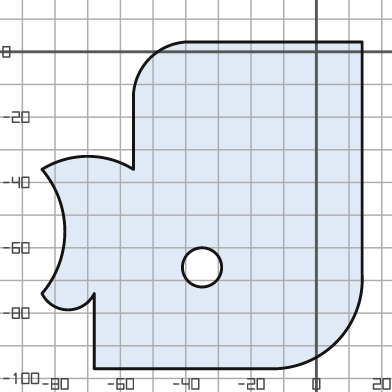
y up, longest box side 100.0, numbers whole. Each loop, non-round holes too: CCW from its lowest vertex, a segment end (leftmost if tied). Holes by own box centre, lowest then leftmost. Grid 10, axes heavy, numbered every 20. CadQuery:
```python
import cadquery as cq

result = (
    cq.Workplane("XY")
    .moveTo(-68.0, -97.0)
    .lineTo(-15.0, -97.0)
    .threePointArc((6.0, -89.0), (14.0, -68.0))
    .lineTo(14.0, 3.0)
    .lineTo(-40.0, 3.0)
    .threePointArc((-51.0, -2.0), (-56.0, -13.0))
    .lineTo(-56.0, -36.0)
    .threePointArc((-70.0, -32.0), (-84.0, -36.0))
    .threePointArc((-77.0, -55.0), (-84.0, -74.0))
    .threePointArc((-76.0, -79.0), (-68.0, -74.0))
    .close()
    .moveTo(-35.0, -66.0)
    .circle(6.0)
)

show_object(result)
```